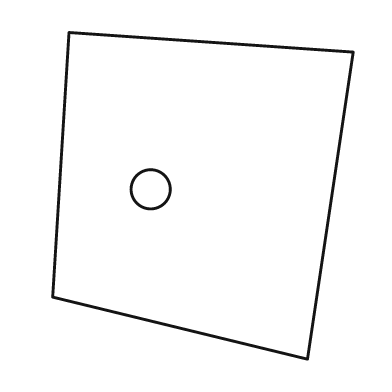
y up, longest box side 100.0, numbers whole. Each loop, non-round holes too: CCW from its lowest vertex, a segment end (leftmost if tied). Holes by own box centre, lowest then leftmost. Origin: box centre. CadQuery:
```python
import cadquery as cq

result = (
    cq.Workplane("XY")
    .moveTo(32.0, -50.0)
    .lineTo(46.0, 44.0)
    .lineTo(-41.0, 50.0)
    .lineTo(-46.0, -31.0)
    .close()
    .moveTo(-16.0, 2.0)
    .circle(6.0)
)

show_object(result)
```